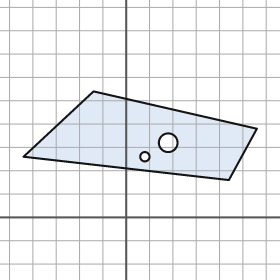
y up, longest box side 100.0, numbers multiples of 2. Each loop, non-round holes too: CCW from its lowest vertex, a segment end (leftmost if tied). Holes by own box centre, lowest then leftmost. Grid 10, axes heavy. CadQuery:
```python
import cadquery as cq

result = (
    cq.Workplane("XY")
    .moveTo(44.0, 16.0)
    .lineTo(56.0, 38.0)
    .lineTo(-14.0, 54.0)
    .lineTo(-44.0, 26.0)
    .close()
    .moveTo(8.0, 26.0)
    .circle(2.0)
    .moveTo(18.0, 32.0)
    .circle(4.0)
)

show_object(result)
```